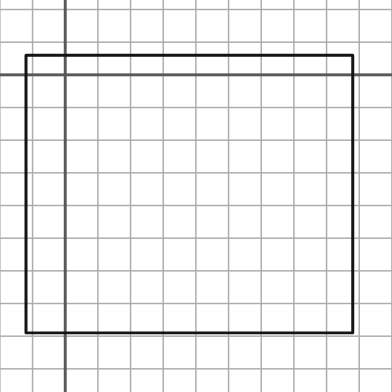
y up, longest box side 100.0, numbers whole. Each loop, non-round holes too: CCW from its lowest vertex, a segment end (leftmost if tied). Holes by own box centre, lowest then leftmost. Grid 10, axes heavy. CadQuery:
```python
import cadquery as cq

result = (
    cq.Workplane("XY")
    .moveTo(-12.0, -79.0)
    .lineTo(88.0, -79.0)
    .lineTo(88.0, 6.0)
    .lineTo(-12.0, 6.0)
    .close()
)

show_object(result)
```